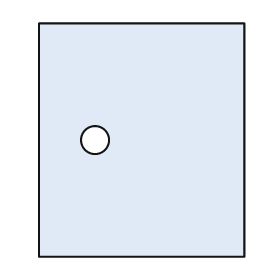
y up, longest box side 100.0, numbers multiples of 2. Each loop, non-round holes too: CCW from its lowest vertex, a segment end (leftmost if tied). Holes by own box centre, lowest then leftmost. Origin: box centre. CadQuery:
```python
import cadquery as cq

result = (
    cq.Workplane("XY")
    .moveTo(-44.0, -50.0)
    .lineTo(44.0, -50.0)
    .lineTo(44.0, 50.0)
    .lineTo(-44.0, 50.0)
    .close()
    .moveTo(-20.0, 0.0)
    .circle(6.0)
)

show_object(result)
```